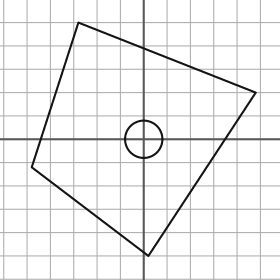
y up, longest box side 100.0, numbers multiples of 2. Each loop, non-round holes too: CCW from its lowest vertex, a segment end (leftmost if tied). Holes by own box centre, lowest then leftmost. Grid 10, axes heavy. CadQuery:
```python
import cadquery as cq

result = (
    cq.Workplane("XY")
    .moveTo(2.0, -50.0)
    .lineTo(48.0, 20.0)
    .lineTo(-28.0, 50.0)
    .lineTo(-48.0, -12.0)
    .close()
    .moveTo(0.0, 0.0)
    .circle(8.0)
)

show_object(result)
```